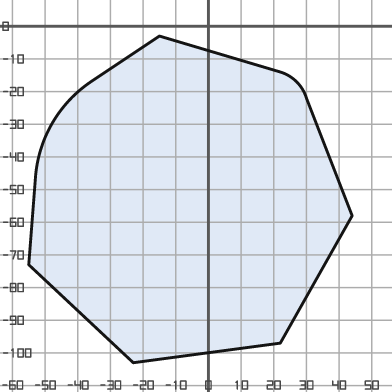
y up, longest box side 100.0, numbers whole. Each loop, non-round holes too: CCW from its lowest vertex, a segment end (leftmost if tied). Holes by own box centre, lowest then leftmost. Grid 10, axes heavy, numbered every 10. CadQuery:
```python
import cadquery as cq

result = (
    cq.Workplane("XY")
    .moveTo(-23.0, -103.0)
    .lineTo(22.0, -97.0)
    .lineTo(44.0, -58.0)
    .lineTo(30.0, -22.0)
    .threePointArc((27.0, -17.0), (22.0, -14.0))
    .lineTo(-15.0, -3.0)
    .lineTo(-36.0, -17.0)
    .threePointArc((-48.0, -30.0), (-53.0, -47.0))
    .lineTo(-55.0, -73.0)
    .close()
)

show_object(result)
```